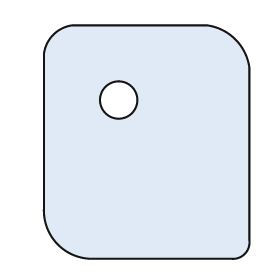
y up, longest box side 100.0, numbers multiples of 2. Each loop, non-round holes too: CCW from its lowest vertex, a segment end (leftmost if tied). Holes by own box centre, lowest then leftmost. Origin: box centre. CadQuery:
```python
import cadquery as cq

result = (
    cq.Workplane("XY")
    .moveTo(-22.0, -50.0)
    .lineTo(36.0, -50.0)
    .threePointArc((42.0, -48.0), (44.0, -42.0))
    .lineTo(44.0, 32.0)
    .threePointArc((38.0, 44.0), (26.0, 50.0))
    .lineTo(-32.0, 50.0)
    .threePointArc((-40.0, 46.0), (-44.0, 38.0))
    .lineTo(-44.0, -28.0)
    .threePointArc((-38.0, -44.0), (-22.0, -50.0))
    .close()
    .moveTo(-12.0, 18.0)
    .circle(8.0)
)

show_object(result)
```